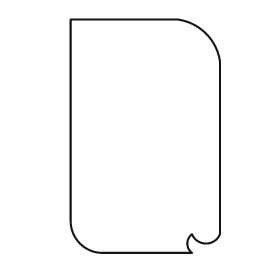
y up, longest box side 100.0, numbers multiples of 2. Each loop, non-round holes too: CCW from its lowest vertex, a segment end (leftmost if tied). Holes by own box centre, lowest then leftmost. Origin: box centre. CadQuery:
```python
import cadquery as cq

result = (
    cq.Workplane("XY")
    .moveTo(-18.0, -50.0)
    .lineTo(20.0, -50.0)
    .threePointArc((18.0, -46.0), (20.0, -42.0))
    .threePointArc((26.0, -46.0), (32.0, -42.0))
    .lineTo(32.0, 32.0)
    .threePointArc((26.0, 44.0), (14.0, 50.0))
    .lineTo(-32.0, 50.0)
    .lineTo(-32.0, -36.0)
    .threePointArc((-28.0, -46.0), (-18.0, -50.0))
    .close()
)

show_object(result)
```